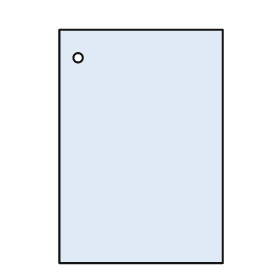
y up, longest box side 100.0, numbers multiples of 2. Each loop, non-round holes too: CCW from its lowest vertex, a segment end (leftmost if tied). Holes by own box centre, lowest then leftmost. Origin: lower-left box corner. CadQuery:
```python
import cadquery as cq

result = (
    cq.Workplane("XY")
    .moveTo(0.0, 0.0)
    .lineTo(70.0, 0.0)
    .lineTo(70.0, 100.0)
    .lineTo(0.0, 100.0)
    .close()
    .moveTo(8.0, 88.0)
    .circle(2.0)
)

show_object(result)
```